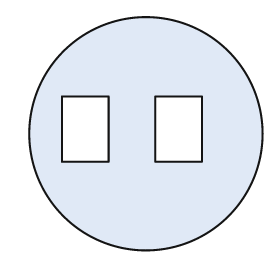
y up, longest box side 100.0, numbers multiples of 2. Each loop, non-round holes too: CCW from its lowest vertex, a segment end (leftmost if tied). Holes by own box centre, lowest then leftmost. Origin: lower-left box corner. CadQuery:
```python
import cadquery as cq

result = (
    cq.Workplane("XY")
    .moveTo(50.0, 50.0)
    .circle(50.0)
    .moveTo(14.0, 38.0)
    .lineTo(34.0, 38.0)
    .lineTo(34.0, 66.0)
    .lineTo(14.0, 66.0)
    .close()
    .moveTo(54.0, 38.0)
    .lineTo(74.0, 38.0)
    .lineTo(74.0, 66.0)
    .lineTo(54.0, 66.0)
    .close()
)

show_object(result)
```